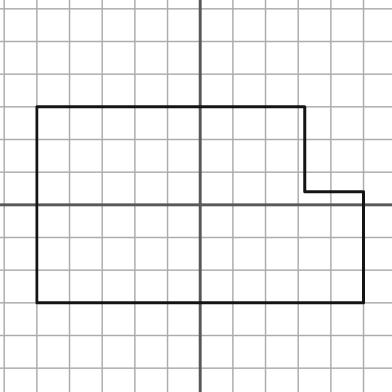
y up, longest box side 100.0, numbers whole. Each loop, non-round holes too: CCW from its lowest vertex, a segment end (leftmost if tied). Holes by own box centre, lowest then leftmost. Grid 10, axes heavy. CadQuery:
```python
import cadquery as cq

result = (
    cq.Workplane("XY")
    .moveTo(-50.0, -30.0)
    .lineTo(50.0, -30.0)
    .lineTo(50.0, 4.0)
    .lineTo(32.0, 4.0)
    .lineTo(32.0, 30.0)
    .lineTo(-50.0, 30.0)
    .close()
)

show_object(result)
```